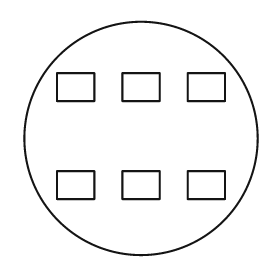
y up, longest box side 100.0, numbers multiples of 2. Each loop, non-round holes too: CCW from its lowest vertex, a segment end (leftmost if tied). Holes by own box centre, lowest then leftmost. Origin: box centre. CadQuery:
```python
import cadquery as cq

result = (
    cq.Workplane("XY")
    .moveTo(0.0, 0.0)
    .circle(50.0)
    .moveTo(-36.0, -26.0)
    .lineTo(-20.0, -26.0)
    .lineTo(-20.0, -14.0)
    .lineTo(-36.0, -14.0)
    .close()
    .moveTo(-8.0, -26.0)
    .lineTo(8.0, -26.0)
    .lineTo(8.0, -14.0)
    .lineTo(-8.0, -14.0)
    .close()
    .moveTo(20.0, -26.0)
    .lineTo(36.0, -26.0)
    .lineTo(36.0, -14.0)
    .lineTo(20.0, -14.0)
    .close()
    .moveTo(-36.0, 16.0)
    .lineTo(-20.0, 16.0)
    .lineTo(-20.0, 28.0)
    .lineTo(-36.0, 28.0)
    .close()
    .moveTo(-8.0, 16.0)
    .lineTo(8.0, 16.0)
    .lineTo(8.0, 28.0)
    .lineTo(-8.0, 28.0)
    .close()
    .moveTo(20.0, 16.0)
    .lineTo(36.0, 16.0)
    .lineTo(36.0, 28.0)
    .lineTo(20.0, 28.0)
    .close()
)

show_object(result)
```